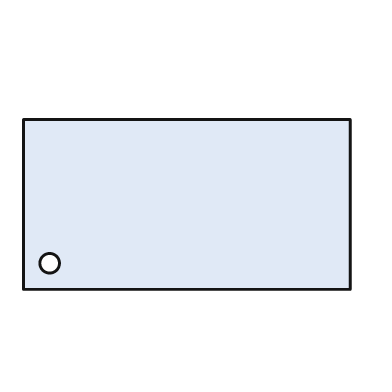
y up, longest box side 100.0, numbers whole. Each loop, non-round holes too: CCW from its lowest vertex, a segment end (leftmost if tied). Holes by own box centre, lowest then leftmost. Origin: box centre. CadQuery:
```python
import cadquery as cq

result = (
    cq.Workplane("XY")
    .moveTo(-50.0, -26.0)
    .lineTo(50.0, -26.0)
    .lineTo(50.0, 26.0)
    .lineTo(-50.0, 26.0)
    .close()
    .moveTo(-42.0, -18.0)
    .circle(3.0)
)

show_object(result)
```